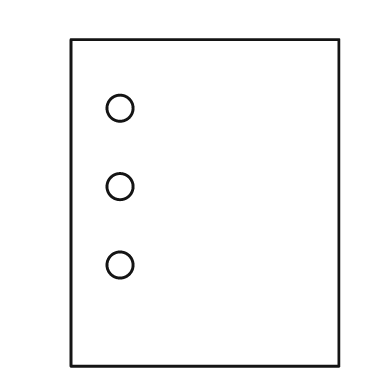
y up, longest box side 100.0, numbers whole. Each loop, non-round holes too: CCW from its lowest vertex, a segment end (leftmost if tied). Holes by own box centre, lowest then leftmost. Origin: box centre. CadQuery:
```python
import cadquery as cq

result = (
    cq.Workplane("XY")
    .moveTo(-41.0, -50.0)
    .lineTo(41.0, -50.0)
    .lineTo(41.0, 50.0)
    .lineTo(-41.0, 50.0)
    .close()
    .moveTo(-26.0, -19.0)
    .circle(4.0)
    .moveTo(-26.0, 5.0)
    .circle(4.0)
    .moveTo(-26.0, 29.0)
    .circle(4.0)
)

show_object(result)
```